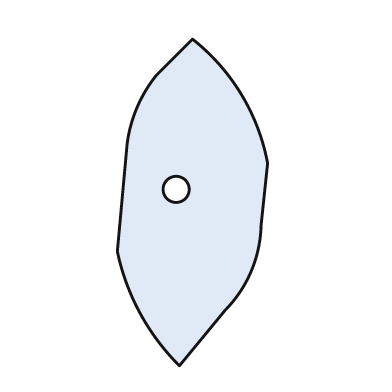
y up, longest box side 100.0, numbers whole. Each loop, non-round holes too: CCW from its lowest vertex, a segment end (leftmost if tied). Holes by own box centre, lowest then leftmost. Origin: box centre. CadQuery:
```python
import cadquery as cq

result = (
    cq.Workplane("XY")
    .moveTo(-4.0, -50.0)
    .lineTo(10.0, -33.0)
    .threePointArc((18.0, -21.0), (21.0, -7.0))
    .lineTo(23.0, 12.0)
    .threePointArc((15.0, 33.0), (0.0, 50.0))
    .lineTo(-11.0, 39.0)
    .threePointArc((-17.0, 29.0), (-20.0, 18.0))
    .lineTo(-23.0, -15.0)
    .threePointArc((-16.0, -34.0), (-4.0, -50.0))
    .close()
    .moveTo(-5.0, 4.0)
    .circle(4.0)
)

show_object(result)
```